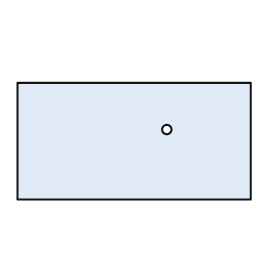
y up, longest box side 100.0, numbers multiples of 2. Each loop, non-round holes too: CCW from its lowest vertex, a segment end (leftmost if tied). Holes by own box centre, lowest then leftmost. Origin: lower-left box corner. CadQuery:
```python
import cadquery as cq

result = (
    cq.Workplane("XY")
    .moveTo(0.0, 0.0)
    .lineTo(100.0, 0.0)
    .lineTo(100.0, 50.0)
    .lineTo(0.0, 50.0)
    .close()
    .moveTo(64.0, 30.0)
    .circle(2.0)
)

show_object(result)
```